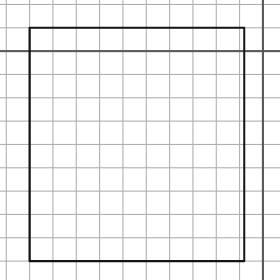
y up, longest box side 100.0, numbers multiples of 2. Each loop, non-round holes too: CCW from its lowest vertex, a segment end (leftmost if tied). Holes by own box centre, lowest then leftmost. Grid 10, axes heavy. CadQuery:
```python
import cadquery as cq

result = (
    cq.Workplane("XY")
    .moveTo(-100.0, -90.0)
    .lineTo(-8.0, -90.0)
    .lineTo(-8.0, 10.0)
    .lineTo(-100.0, 10.0)
    .close()
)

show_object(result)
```